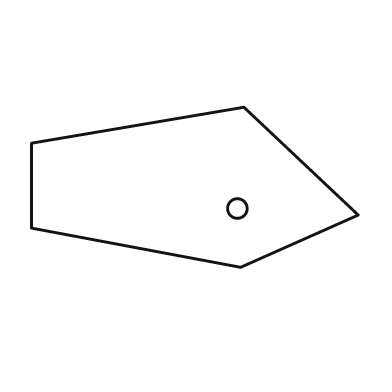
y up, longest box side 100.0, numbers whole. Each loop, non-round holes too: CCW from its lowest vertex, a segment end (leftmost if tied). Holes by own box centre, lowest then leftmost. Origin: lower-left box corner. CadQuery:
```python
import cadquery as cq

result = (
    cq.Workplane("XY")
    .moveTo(64.0, 0.0)
    .lineTo(100.0, 16.0)
    .lineTo(65.0, 49.0)
    .lineTo(0.0, 38.0)
    .lineTo(0.0, 12.0)
    .close()
    .moveTo(63.0, 18.0)
    .circle(3.0)
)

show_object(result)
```